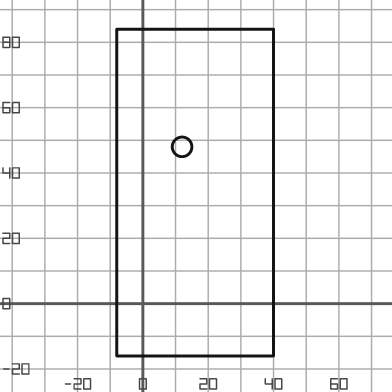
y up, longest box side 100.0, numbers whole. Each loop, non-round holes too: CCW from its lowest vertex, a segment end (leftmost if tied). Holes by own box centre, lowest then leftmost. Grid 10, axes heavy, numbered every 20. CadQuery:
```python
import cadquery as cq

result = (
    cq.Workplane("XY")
    .moveTo(-8.0, -16.0)
    .lineTo(40.0, -16.0)
    .lineTo(40.0, 84.0)
    .lineTo(-8.0, 84.0)
    .close()
    .moveTo(12.0, 48.0)
    .circle(3.0)
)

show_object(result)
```